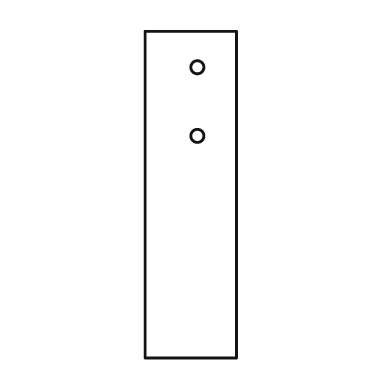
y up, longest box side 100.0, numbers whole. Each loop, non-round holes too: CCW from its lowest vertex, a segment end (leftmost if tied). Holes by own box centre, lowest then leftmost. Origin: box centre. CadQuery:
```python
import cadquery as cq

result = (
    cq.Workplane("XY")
    .moveTo(-14.0, -50.0)
    .lineTo(14.0, -50.0)
    .lineTo(14.0, 50.0)
    .lineTo(-14.0, 50.0)
    .close()
    .moveTo(2.0, 18.0)
    .circle(2.0)
    .moveTo(2.0, 39.0)
    .circle(2.0)
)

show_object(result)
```